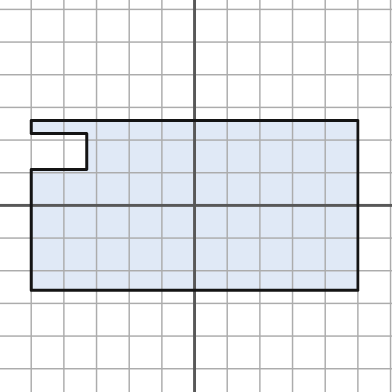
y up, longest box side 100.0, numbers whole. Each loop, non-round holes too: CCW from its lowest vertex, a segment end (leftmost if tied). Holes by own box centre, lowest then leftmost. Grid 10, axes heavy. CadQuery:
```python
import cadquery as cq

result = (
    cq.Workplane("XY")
    .moveTo(-50.0, -26.0)
    .lineTo(50.0, -26.0)
    .lineTo(50.0, 26.0)
    .lineTo(-50.0, 26.0)
    .lineTo(-50.0, 22.0)
    .lineTo(-33.0, 22.0)
    .lineTo(-33.0, 11.0)
    .lineTo(-50.0, 11.0)
    .close()
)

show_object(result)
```